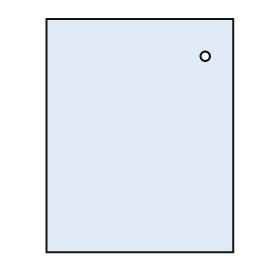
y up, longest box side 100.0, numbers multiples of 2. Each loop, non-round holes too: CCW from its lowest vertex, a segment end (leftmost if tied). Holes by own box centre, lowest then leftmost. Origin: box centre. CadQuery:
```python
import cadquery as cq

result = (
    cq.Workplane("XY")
    .moveTo(-40.0, -50.0)
    .lineTo(40.0, -50.0)
    .lineTo(40.0, 50.0)
    .lineTo(-40.0, 50.0)
    .close()
    .moveTo(28.0, 34.0)
    .circle(2.0)
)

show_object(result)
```